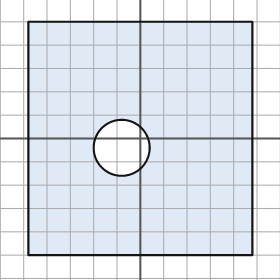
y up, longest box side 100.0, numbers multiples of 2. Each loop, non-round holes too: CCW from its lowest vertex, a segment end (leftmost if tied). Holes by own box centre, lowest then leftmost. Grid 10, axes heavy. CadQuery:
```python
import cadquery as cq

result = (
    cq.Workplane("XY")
    .moveTo(-48.0, -50.0)
    .lineTo(48.0, -50.0)
    .lineTo(48.0, 50.0)
    .lineTo(-48.0, 50.0)
    .close()
    .moveTo(-8.0, -4.0)
    .circle(12.0)
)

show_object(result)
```